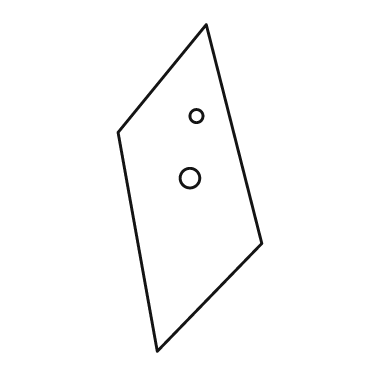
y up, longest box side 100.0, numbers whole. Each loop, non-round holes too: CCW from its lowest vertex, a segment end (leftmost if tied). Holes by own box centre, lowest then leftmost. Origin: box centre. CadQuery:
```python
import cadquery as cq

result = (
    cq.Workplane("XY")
    .moveTo(-10.0, -50.0)
    .lineTo(22.0, -17.0)
    .lineTo(5.0, 50.0)
    .lineTo(-22.0, 17.0)
    .close()
    .moveTo(0.0, 3.0)
    .circle(3.0)
    .moveTo(2.0, 22.0)
    .circle(2.0)
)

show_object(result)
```